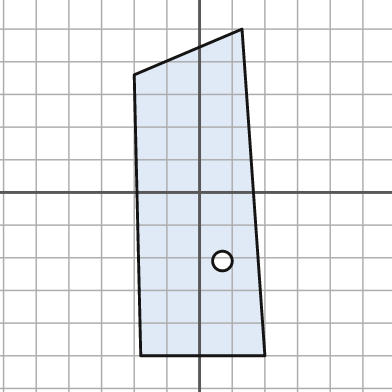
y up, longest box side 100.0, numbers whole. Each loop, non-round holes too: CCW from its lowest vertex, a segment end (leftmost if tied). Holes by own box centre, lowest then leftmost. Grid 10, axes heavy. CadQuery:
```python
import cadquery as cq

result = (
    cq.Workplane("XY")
    .moveTo(-18.0, -50.0)
    .lineTo(20.0, -50.0)
    .lineTo(13.0, 50.0)
    .lineTo(-20.0, 36.0)
    .close()
    .moveTo(7.0, -21.0)
    .circle(3.0)
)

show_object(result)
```